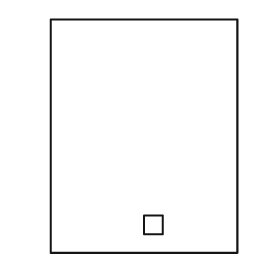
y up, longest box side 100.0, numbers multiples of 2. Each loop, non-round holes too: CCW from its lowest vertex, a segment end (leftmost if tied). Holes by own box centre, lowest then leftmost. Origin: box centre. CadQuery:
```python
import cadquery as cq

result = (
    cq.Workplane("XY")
    .moveTo(-40.0, -50.0)
    .lineTo(40.0, -50.0)
    .lineTo(40.0, 50.0)
    .lineTo(-40.0, 50.0)
    .close()
    .moveTo(0.0, -42.0)
    .lineTo(8.0, -42.0)
    .lineTo(8.0, -34.0)
    .lineTo(0.0, -34.0)
    .close()
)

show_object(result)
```